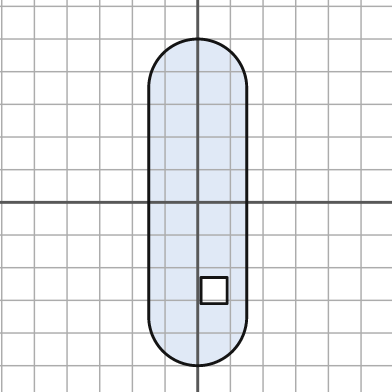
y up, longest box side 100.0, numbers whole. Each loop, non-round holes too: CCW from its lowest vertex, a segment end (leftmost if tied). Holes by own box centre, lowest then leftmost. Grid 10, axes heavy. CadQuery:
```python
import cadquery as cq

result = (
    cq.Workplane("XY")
    .moveTo(-15.0, -35.0)
    .threePointArc((0.0, -50.0), (15.0, -35.0))
    .lineTo(15.0, 35.0)
    .threePointArc((0.0, 50.0), (-15.0, 35.0))
    .close()
    .moveTo(1.0, -31.0)
    .lineTo(9.0, -31.0)
    .lineTo(9.0, -23.0)
    .lineTo(1.0, -23.0)
    .close()
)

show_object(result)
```